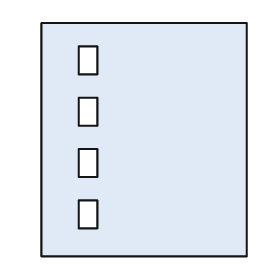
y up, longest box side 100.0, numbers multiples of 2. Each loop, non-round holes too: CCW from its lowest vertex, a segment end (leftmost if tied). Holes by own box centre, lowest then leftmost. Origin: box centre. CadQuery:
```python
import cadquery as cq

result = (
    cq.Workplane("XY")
    .moveTo(-44.0, -50.0)
    .lineTo(44.0, -50.0)
    .lineTo(44.0, 50.0)
    .lineTo(-44.0, 50.0)
    .close()
    .moveTo(-28.0, -38.0)
    .lineTo(-20.0, -38.0)
    .lineTo(-20.0, -26.0)
    .lineTo(-28.0, -26.0)
    .close()
    .moveTo(-28.0, -16.0)
    .lineTo(-20.0, -16.0)
    .lineTo(-20.0, -4.0)
    .lineTo(-28.0, -4.0)
    .close()
    .moveTo(-28.0, 6.0)
    .lineTo(-20.0, 6.0)
    .lineTo(-20.0, 18.0)
    .lineTo(-28.0, 18.0)
    .close()
    .moveTo(-28.0, 28.0)
    .lineTo(-20.0, 28.0)
    .lineTo(-20.0, 40.0)
    .lineTo(-28.0, 40.0)
    .close()
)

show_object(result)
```